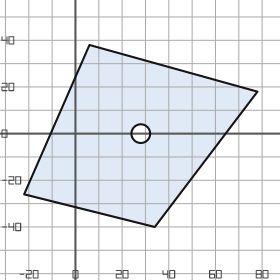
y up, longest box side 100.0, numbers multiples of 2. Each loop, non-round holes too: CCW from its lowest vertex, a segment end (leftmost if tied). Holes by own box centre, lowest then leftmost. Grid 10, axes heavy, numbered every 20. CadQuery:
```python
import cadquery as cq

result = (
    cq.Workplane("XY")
    .moveTo(34.0, -40.0)
    .lineTo(78.0, 18.0)
    .lineTo(6.0, 38.0)
    .lineTo(-22.0, -26.0)
    .close()
    .moveTo(28.0, 0.0)
    .circle(4.0)
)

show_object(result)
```